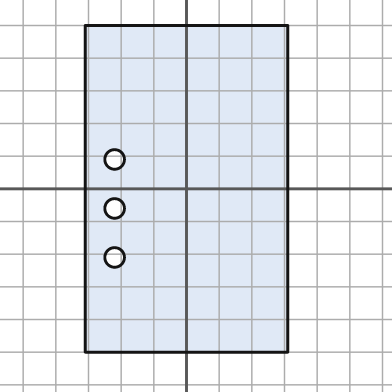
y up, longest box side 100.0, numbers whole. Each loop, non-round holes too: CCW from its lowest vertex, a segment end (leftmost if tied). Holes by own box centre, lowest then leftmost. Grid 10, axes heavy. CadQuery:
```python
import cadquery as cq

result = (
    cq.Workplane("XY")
    .moveTo(-31.0, -50.0)
    .lineTo(31.0, -50.0)
    .lineTo(31.0, 50.0)
    .lineTo(-31.0, 50.0)
    .close()
    .moveTo(-22.0, -21.0)
    .circle(3.0)
    .moveTo(-22.0, -6.0)
    .circle(3.0)
    .moveTo(-22.0, 9.0)
    .circle(3.0)
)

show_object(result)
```